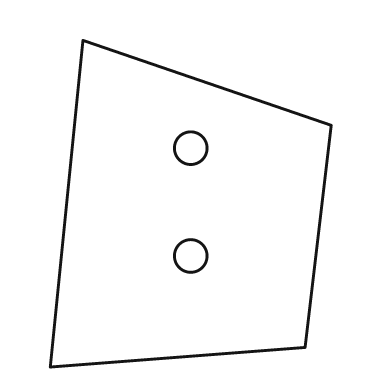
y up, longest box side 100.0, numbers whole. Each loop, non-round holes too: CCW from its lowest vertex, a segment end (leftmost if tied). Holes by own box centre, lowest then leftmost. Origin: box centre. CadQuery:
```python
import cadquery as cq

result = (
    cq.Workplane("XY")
    .moveTo(-43.0, -50.0)
    .lineTo(35.0, -44.0)
    .lineTo(43.0, 24.0)
    .lineTo(-33.0, 50.0)
    .close()
    .moveTo(0.0, -16.0)
    .circle(5.0)
    .moveTo(0.0, 17.0)
    .circle(5.0)
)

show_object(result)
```